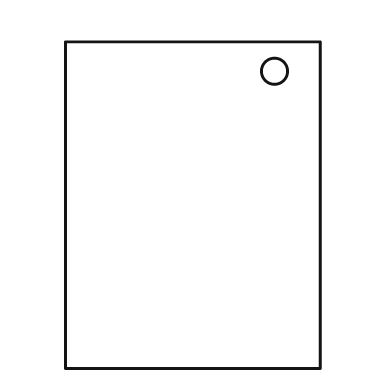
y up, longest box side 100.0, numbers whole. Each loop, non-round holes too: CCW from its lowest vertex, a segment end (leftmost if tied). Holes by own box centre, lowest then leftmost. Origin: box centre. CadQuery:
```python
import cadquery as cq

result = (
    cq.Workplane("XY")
    .moveTo(-39.0, -50.0)
    .lineTo(39.0, -50.0)
    .lineTo(39.0, 50.0)
    .lineTo(-39.0, 50.0)
    .close()
    .moveTo(25.0, 41.0)
    .circle(4.0)
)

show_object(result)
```